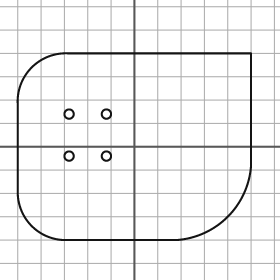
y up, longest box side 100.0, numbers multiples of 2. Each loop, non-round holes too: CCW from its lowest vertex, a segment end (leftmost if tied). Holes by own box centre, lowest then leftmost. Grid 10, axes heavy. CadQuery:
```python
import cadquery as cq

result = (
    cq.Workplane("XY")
    .moveTo(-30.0, -40.0)
    .lineTo(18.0, -40.0)
    .threePointArc((40.0, -30.0), (50.0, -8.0))
    .lineTo(50.0, 40.0)
    .lineTo(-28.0, 40.0)
    .threePointArc((-44.0, 34.0), (-50.0, 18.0))
    .lineTo(-50.0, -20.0)
    .threePointArc((-44.0, -34.0), (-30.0, -40.0))
    .close()
    .moveTo(-28.0, -4.0)
    .circle(2.0)
    .moveTo(-12.0, -4.0)
    .circle(2.0)
    .moveTo(-28.0, 14.0)
    .circle(2.0)
    .moveTo(-12.0, 14.0)
    .circle(2.0)
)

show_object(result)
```